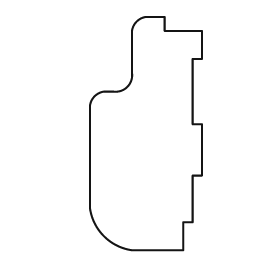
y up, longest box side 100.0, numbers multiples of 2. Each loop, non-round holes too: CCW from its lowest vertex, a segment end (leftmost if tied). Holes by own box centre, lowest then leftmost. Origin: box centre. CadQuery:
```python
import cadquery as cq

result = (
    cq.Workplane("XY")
    .moveTo(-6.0, -50.0)
    .lineTo(16.0, -50.0)
    .lineTo(16.0, -38.0)
    .lineTo(20.0, -38.0)
    .lineTo(20.0, -18.0)
    .lineTo(24.0, -18.0)
    .lineTo(24.0, 4.0)
    .lineTo(20.0, 4.0)
    .lineTo(20.0, 32.0)
    .lineTo(24.0, 32.0)
    .lineTo(24.0, 44.0)
    .lineTo(8.0, 44.0)
    .lineTo(8.0, 50.0)
    .lineTo(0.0, 50.0)
    .threePointArc((-4.0, 48.0), (-6.0, 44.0))
    .lineTo(-6.0, 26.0)
    .threePointArc((-8.0, 20.0), (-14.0, 18.0))
    .lineTo(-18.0, 18.0)
    .threePointArc((-22.0, 16.0), (-24.0, 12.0))
    .lineTo(-24.0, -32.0)
    .threePointArc((-18.0, -44.0), (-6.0, -50.0))
    .close()
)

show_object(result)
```